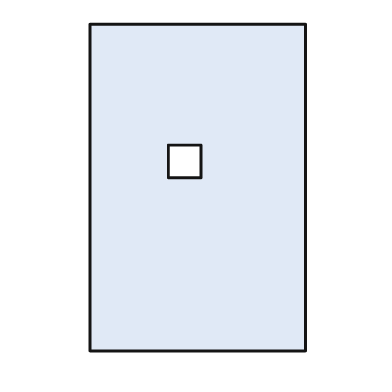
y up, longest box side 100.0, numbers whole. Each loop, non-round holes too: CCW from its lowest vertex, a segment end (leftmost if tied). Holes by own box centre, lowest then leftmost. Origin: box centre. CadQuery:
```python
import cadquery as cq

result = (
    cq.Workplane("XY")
    .moveTo(-33.0, -50.0)
    .lineTo(33.0, -50.0)
    .lineTo(33.0, 50.0)
    .lineTo(-33.0, 50.0)
    .close()
    .moveTo(-9.0, 3.0)
    .lineTo(1.0, 3.0)
    .lineTo(1.0, 13.0)
    .lineTo(-9.0, 13.0)
    .close()
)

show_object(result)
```